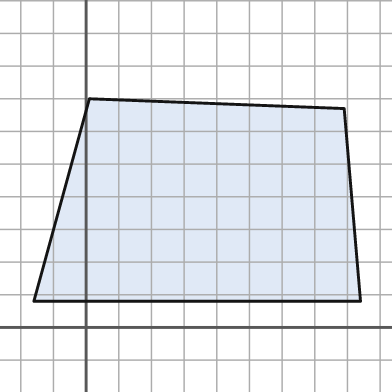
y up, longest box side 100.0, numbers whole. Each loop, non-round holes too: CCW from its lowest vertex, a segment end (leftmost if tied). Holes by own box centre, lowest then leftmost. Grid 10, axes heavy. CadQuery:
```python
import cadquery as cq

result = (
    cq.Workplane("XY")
    .moveTo(-16.0, 8.0)
    .lineTo(84.0, 8.0)
    .lineTo(79.0, 67.0)
    .lineTo(1.0, 70.0)
    .close()
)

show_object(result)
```